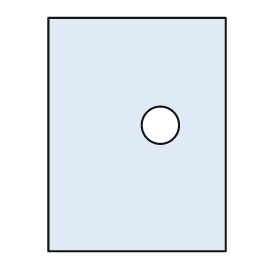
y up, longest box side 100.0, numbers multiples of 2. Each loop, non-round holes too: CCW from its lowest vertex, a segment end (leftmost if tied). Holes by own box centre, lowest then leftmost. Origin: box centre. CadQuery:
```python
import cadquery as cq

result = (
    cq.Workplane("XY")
    .moveTo(-38.0, -50.0)
    .lineTo(38.0, -50.0)
    .lineTo(38.0, 50.0)
    .lineTo(-38.0, 50.0)
    .close()
    .moveTo(10.0, 4.0)
    .circle(8.0)
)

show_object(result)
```